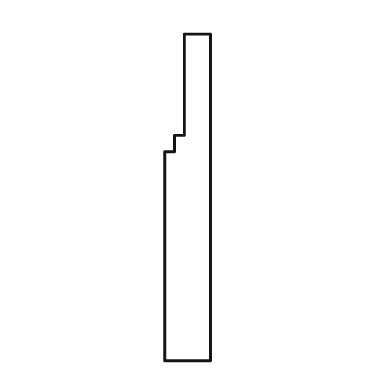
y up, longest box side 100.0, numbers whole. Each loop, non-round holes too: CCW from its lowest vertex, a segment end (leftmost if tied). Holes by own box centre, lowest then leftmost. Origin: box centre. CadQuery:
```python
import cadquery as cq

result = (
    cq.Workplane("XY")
    .moveTo(-7.0, -50.0)
    .lineTo(7.0, -50.0)
    .lineTo(7.0, 50.0)
    .lineTo(-1.0, 50.0)
    .lineTo(-1.0, 19.0)
    .lineTo(-4.0, 19.0)
    .lineTo(-4.0, 14.0)
    .lineTo(-7.0, 14.0)
    .close()
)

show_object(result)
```